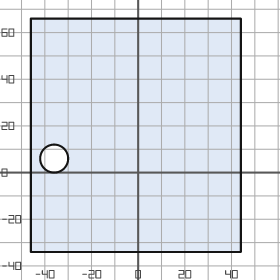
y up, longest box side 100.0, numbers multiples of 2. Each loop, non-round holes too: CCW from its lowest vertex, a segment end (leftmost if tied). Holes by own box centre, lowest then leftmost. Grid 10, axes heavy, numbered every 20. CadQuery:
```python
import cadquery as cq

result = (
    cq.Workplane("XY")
    .moveTo(-46.0, -34.0)
    .lineTo(44.0, -34.0)
    .lineTo(44.0, 66.0)
    .lineTo(-46.0, 66.0)
    .close()
    .moveTo(-36.0, 6.0)
    .circle(6.0)
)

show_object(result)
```